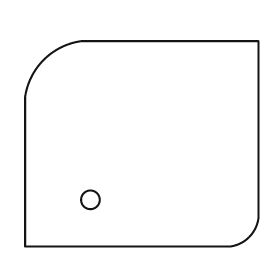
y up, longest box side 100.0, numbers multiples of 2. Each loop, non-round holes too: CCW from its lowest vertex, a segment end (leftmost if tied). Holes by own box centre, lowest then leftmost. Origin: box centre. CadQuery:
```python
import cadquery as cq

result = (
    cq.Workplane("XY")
    .moveTo(-50.0, -44.0)
    .lineTo(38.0, -44.0)
    .threePointArc((46.0, -40.0), (50.0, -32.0))
    .lineTo(50.0, 44.0)
    .lineTo(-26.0, 44.0)
    .threePointArc((-42.0, 36.0), (-50.0, 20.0))
    .close()
    .moveTo(-22.0, -24.0)
    .circle(4.0)
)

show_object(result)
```